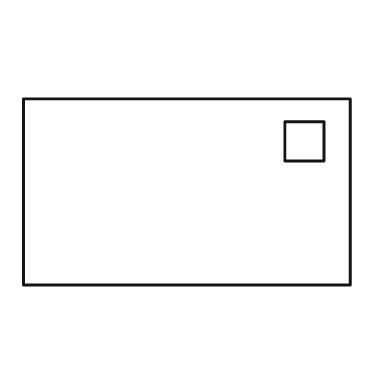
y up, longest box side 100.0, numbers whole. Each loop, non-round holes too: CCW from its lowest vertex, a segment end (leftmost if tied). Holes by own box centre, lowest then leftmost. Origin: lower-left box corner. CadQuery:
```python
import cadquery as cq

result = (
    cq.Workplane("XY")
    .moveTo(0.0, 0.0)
    .lineTo(100.0, 0.0)
    .lineTo(100.0, 57.0)
    .lineTo(0.0, 57.0)
    .close()
    .moveTo(80.0, 38.0)
    .lineTo(92.0, 38.0)
    .lineTo(92.0, 50.0)
    .lineTo(80.0, 50.0)
    .close()
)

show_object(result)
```